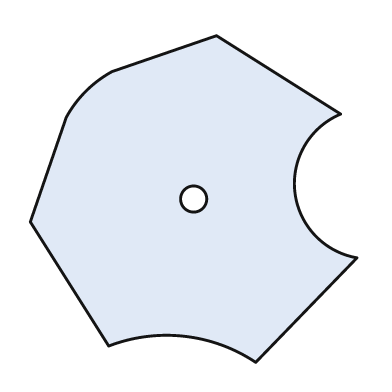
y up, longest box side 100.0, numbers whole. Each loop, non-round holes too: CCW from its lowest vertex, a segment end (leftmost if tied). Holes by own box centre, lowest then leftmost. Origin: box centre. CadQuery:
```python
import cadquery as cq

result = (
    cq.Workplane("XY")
    .moveTo(19.0, -50.0)
    .lineTo(50.0, -18.0)
    .threePointArc((31.0, 2.0), (45.0, 26.0))
    .lineTo(7.0, 50.0)
    .lineTo(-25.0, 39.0)
    .threePointArc((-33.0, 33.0), (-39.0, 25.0))
    .lineTo(-50.0, -7.0)
    .lineTo(-26.0, -45.0)
    .threePointArc((-3.0, -42.0), (19.0, -50.0))
    .close()
    .moveTo(0.0, 0.0)
    .circle(4.0)
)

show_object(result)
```